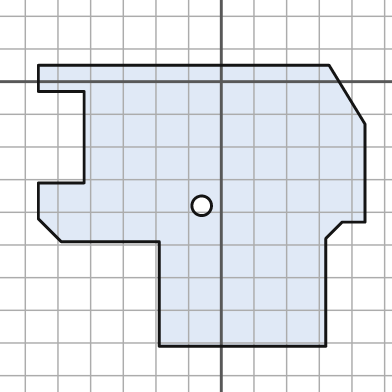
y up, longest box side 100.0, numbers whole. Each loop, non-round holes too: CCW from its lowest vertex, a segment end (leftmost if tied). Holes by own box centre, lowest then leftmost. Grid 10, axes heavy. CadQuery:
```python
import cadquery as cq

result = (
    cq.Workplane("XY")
    .moveTo(-19.0, -81.0)
    .lineTo(32.0, -81.0)
    .lineTo(32.0, -48.0)
    .lineTo(37.0, -43.0)
    .lineTo(44.0, -43.0)
    .lineTo(44.0, -13.0)
    .lineTo(33.0, 5.0)
    .lineTo(-56.0, 5.0)
    .lineTo(-56.0, -3.0)
    .lineTo(-42.0, -3.0)
    .lineTo(-42.0, -31.0)
    .lineTo(-56.0, -31.0)
    .lineTo(-56.0, -42.0)
    .lineTo(-49.0, -49.0)
    .lineTo(-19.0, -49.0)
    .close()
    .moveTo(-6.0, -38.0)
    .circle(3.0)
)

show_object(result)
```